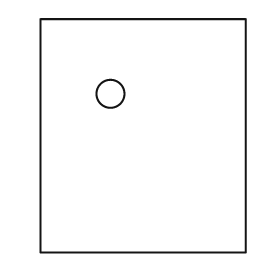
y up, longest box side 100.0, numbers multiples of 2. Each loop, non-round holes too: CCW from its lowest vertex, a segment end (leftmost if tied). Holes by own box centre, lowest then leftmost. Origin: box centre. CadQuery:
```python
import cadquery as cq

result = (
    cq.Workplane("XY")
    .moveTo(-44.0, -50.0)
    .lineTo(44.0, -50.0)
    .lineTo(44.0, 50.0)
    .lineTo(-44.0, 50.0)
    .close()
    .moveTo(-14.0, 18.0)
    .circle(6.0)
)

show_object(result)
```